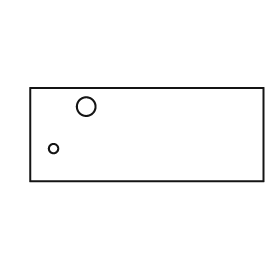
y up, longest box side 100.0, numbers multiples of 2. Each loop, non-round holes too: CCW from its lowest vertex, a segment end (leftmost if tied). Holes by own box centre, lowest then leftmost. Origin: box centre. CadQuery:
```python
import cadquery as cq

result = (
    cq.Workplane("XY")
    .moveTo(-50.0, -20.0)
    .lineTo(50.0, -20.0)
    .lineTo(50.0, 20.0)
    .lineTo(-50.0, 20.0)
    .close()
    .moveTo(-40.0, -6.0)
    .circle(2.0)
    .moveTo(-26.0, 12.0)
    .circle(4.0)
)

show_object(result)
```